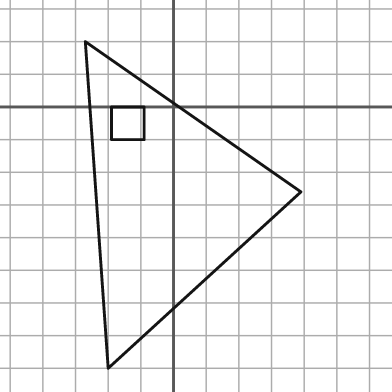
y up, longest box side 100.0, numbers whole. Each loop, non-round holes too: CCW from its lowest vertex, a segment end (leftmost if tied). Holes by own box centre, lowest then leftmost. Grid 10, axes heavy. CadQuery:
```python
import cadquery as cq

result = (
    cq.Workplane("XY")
    .moveTo(-20.0, -80.0)
    .lineTo(39.0, -26.0)
    .lineTo(-27.0, 20.0)
    .close()
    .moveTo(-19.0, -10.0)
    .lineTo(-9.0, -10.0)
    .lineTo(-9.0, 0.0)
    .lineTo(-19.0, 0.0)
    .close()
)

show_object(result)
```